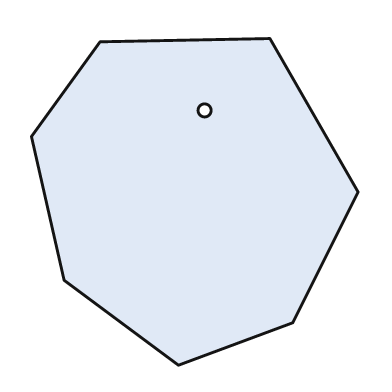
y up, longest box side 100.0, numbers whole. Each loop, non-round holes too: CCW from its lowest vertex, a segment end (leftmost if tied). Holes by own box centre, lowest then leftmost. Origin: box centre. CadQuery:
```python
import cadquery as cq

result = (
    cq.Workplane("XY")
    .moveTo(-5.0, -50.0)
    .lineTo(30.0, -37.0)
    .lineTo(50.0, 3.0)
    .lineTo(23.0, 50.0)
    .lineTo(-29.0, 49.0)
    .lineTo(-50.0, 20.0)
    .lineTo(-40.0, -24.0)
    .close()
    .moveTo(3.0, 28.0)
    .circle(2.0)
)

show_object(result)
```